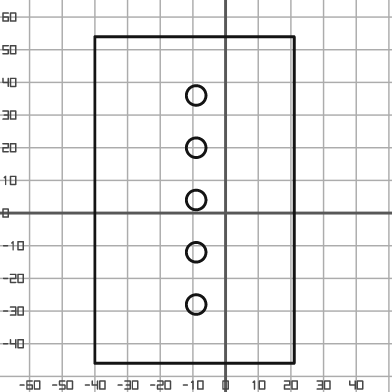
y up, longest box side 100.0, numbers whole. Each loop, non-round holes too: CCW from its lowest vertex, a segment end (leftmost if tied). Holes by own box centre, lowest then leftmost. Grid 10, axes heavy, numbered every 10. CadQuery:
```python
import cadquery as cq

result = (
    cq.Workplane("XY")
    .moveTo(-40.0, -46.0)
    .lineTo(21.0, -46.0)
    .lineTo(21.0, 54.0)
    .lineTo(-40.0, 54.0)
    .close()
    .moveTo(-9.0, -28.0)
    .circle(3.0)
    .moveTo(-9.0, -12.0)
    .circle(3.0)
    .moveTo(-9.0, 4.0)
    .circle(3.0)
    .moveTo(-9.0, 20.0)
    .circle(3.0)
    .moveTo(-9.0, 36.0)
    .circle(3.0)
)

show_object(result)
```